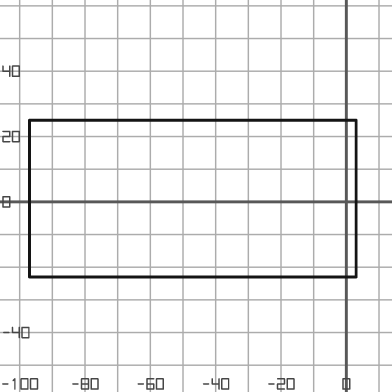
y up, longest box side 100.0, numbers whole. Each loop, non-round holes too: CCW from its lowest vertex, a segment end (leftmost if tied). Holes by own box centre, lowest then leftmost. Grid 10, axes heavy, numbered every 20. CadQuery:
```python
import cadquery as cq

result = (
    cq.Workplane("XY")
    .moveTo(-97.0, -23.0)
    .lineTo(3.0, -23.0)
    .lineTo(3.0, 25.0)
    .lineTo(-97.0, 25.0)
    .close()
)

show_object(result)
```